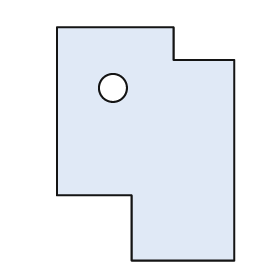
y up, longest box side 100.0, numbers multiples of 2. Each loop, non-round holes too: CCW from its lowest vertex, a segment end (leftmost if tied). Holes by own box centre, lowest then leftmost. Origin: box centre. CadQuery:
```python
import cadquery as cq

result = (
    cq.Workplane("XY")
    .moveTo(-6.0, -50.0)
    .lineTo(38.0, -50.0)
    .lineTo(38.0, 36.0)
    .lineTo(12.0, 36.0)
    .lineTo(12.0, 50.0)
    .lineTo(-38.0, 50.0)
    .lineTo(-38.0, -22.0)
    .lineTo(-6.0, -22.0)
    .close()
    .moveTo(-14.0, 24.0)
    .circle(6.0)
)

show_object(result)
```